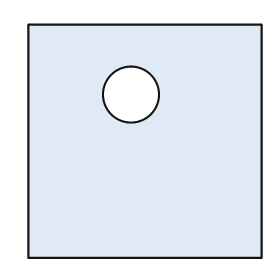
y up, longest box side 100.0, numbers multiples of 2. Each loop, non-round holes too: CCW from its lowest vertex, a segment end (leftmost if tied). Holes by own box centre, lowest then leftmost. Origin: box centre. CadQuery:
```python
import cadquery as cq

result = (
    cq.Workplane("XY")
    .moveTo(-50.0, -50.0)
    .lineTo(50.0, -50.0)
    .lineTo(50.0, 50.0)
    .lineTo(-50.0, 50.0)
    .close()
    .moveTo(-6.0, 20.0)
    .circle(12.0)
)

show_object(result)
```